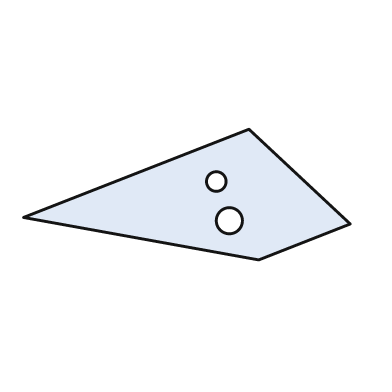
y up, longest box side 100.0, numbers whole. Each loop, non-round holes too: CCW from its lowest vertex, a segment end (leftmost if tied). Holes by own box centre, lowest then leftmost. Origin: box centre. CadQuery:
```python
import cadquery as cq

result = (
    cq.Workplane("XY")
    .moveTo(22.0, -20.0)
    .lineTo(50.0, -9.0)
    .lineTo(19.0, 20.0)
    .lineTo(-50.0, -7.0)
    .close()
    .moveTo(13.0, -8.0)
    .circle(4.0)
    .moveTo(9.0, 4.0)
    .circle(3.0)
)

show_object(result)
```